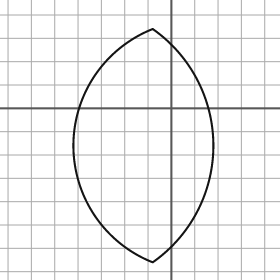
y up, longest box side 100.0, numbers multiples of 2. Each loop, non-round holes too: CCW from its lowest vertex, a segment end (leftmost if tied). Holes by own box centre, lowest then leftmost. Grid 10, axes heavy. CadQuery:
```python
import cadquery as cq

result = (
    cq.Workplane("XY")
    .moveTo(-8.0, -66.0)
    .threePointArc((18.0, -16.0), (-8.0, 34.0))
    .threePointArc((-42.0, -16.0), (-8.0, -66.0))
    .close()
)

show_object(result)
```